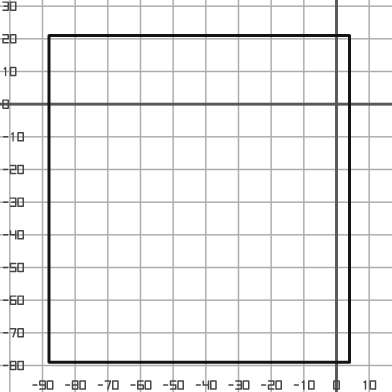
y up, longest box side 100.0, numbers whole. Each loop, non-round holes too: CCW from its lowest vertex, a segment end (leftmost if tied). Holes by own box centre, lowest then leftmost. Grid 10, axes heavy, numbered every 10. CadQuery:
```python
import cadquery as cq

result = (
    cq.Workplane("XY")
    .moveTo(-88.0, -79.0)
    .lineTo(4.0, -79.0)
    .lineTo(4.0, 21.0)
    .lineTo(-88.0, 21.0)
    .close()
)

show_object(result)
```